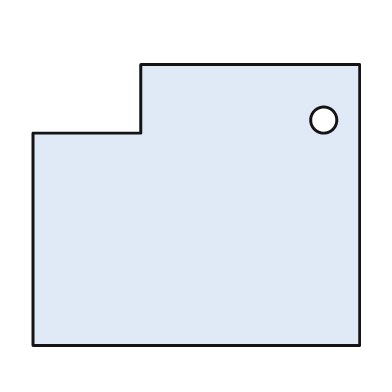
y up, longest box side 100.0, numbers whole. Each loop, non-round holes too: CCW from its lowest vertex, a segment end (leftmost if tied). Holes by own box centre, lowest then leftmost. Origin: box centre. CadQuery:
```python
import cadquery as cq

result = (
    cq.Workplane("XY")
    .moveTo(-50.0, -43.0)
    .lineTo(50.0, -43.0)
    .lineTo(50.0, 43.0)
    .lineTo(-17.0, 43.0)
    .lineTo(-17.0, 22.0)
    .lineTo(-50.0, 22.0)
    .close()
    .moveTo(39.0, 26.0)
    .circle(4.0)
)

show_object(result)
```